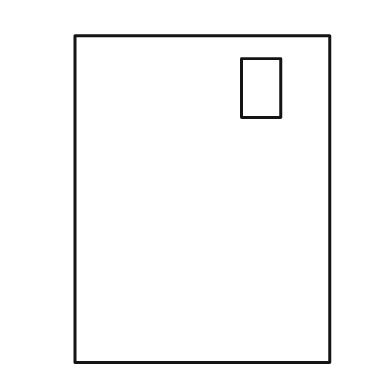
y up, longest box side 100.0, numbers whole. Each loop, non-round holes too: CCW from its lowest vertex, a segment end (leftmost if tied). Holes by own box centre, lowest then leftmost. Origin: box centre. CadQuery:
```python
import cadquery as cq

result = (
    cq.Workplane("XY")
    .moveTo(-39.0, -50.0)
    .lineTo(39.0, -50.0)
    .lineTo(39.0, 50.0)
    .lineTo(-39.0, 50.0)
    .close()
    .moveTo(12.0, 25.0)
    .lineTo(24.0, 25.0)
    .lineTo(24.0, 43.0)
    .lineTo(12.0, 43.0)
    .close()
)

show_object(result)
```